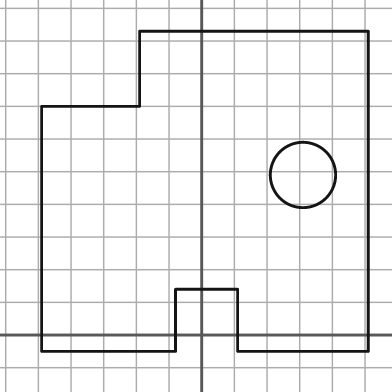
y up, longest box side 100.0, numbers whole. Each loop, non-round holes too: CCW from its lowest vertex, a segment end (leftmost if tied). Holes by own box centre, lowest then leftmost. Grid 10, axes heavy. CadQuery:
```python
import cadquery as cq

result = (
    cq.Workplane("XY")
    .moveTo(-49.0, -5.0)
    .lineTo(-8.0, -5.0)
    .lineTo(-8.0, 14.0)
    .lineTo(11.0, 14.0)
    .lineTo(11.0, -5.0)
    .lineTo(51.0, -5.0)
    .lineTo(51.0, 93.0)
    .lineTo(-19.0, 93.0)
    .lineTo(-19.0, 70.0)
    .lineTo(-49.0, 70.0)
    .close()
    .moveTo(31.0, 49.0)
    .circle(10.0)
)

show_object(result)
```